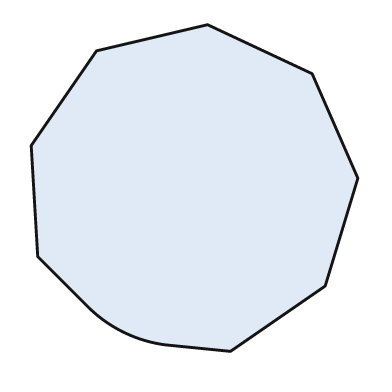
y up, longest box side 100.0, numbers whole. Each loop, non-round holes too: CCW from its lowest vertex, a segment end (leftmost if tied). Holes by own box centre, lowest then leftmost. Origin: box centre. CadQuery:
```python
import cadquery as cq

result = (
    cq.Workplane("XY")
    .moveTo(11.0, -50.0)
    .lineTo(40.0, -30.0)
    .lineTo(50.0, 3.0)
    .lineTo(36.0, 35.0)
    .lineTo(4.0, 50.0)
    .lineTo(-30.0, 42.0)
    .lineTo(-50.0, 13.0)
    .lineTo(-48.0, -21.0)
    .lineTo(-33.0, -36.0)
    .threePointArc((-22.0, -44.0), (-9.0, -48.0))
    .close()
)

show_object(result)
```